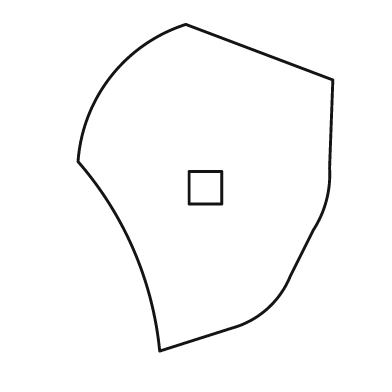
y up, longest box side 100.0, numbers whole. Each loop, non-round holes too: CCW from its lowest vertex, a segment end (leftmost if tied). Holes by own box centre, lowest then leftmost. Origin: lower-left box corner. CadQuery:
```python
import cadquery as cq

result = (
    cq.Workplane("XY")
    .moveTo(25.0, 0.0)
    .lineTo(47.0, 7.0)
    .threePointArc((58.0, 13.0), (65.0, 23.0))
    .lineTo(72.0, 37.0)
    .threePointArc((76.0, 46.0), (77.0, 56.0))
    .lineTo(78.0, 83.0)
    .lineTo(33.0, 100.0)
    .threePointArc((10.0, 84.0), (0.0, 58.0))
    .threePointArc((17.0, 31.0), (25.0, 0.0))
    .close()
    .moveTo(34.0, 45.0)
    .lineTo(44.0, 45.0)
    .lineTo(44.0, 55.0)
    .lineTo(34.0, 55.0)
    .close()
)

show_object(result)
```